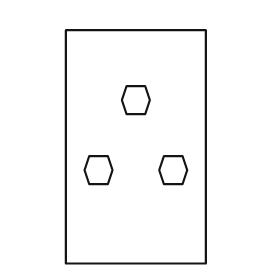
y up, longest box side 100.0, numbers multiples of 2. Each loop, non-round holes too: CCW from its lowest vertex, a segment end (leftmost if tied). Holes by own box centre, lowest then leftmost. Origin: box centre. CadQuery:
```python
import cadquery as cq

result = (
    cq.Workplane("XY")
    .moveTo(-30.0, -50.0)
    .lineTo(30.0, -50.0)
    .lineTo(30.0, 50.0)
    .lineTo(-30.0, 50.0)
    .close()
    .moveTo(-20.0, -16.0)
    .lineTo(-12.0, -16.0)
    .lineTo(-10.0, -10.0)
    .lineTo(-12.0, -4.0)
    .lineTo(-20.0, -4.0)
    .lineTo(-22.0, -10.0)
    .close()
    .moveTo(12.0, -16.0)
    .lineTo(20.0, -16.0)
    .lineTo(22.0, -10.0)
    .lineTo(20.0, -4.0)
    .lineTo(12.0, -4.0)
    .lineTo(10.0, -10.0)
    .close()
    .moveTo(-4.0, 14.0)
    .lineTo(4.0, 14.0)
    .lineTo(6.0, 20.0)
    .lineTo(4.0, 26.0)
    .lineTo(-4.0, 26.0)
    .lineTo(-6.0, 20.0)
    .close()
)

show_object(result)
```